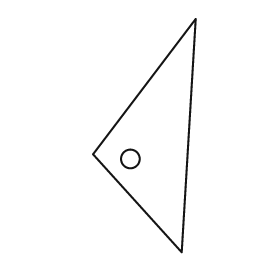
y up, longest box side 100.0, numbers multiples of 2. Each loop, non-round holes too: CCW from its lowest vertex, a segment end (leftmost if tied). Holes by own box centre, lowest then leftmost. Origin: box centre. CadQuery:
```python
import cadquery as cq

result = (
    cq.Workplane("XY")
    .moveTo(16.0, -50.0)
    .lineTo(22.0, 50.0)
    .lineTo(-22.0, -8.0)
    .close()
    .moveTo(-6.0, -10.0)
    .circle(4.0)
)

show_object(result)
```